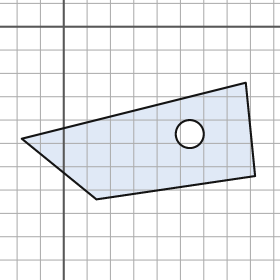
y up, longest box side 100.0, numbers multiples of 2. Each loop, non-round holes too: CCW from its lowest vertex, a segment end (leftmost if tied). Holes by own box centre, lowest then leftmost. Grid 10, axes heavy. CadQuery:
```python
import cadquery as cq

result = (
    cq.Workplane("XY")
    .moveTo(14.0, -74.0)
    .lineTo(82.0, -64.0)
    .lineTo(78.0, -24.0)
    .lineTo(-18.0, -48.0)
    .close()
    .moveTo(54.0, -46.0)
    .circle(6.0)
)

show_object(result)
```